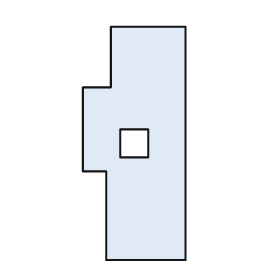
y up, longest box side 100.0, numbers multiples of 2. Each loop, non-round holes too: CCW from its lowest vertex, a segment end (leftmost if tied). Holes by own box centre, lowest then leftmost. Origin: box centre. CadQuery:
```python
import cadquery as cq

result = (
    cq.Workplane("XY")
    .moveTo(-12.0, -50.0)
    .lineTo(22.0, -50.0)
    .lineTo(22.0, 50.0)
    .lineTo(-10.0, 50.0)
    .lineTo(-10.0, 24.0)
    .lineTo(-22.0, 24.0)
    .lineTo(-22.0, -12.0)
    .lineTo(-12.0, -12.0)
    .close()
    .moveTo(-6.0, -6.0)
    .lineTo(6.0, -6.0)
    .lineTo(6.0, 6.0)
    .lineTo(-6.0, 6.0)
    .close()
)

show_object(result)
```